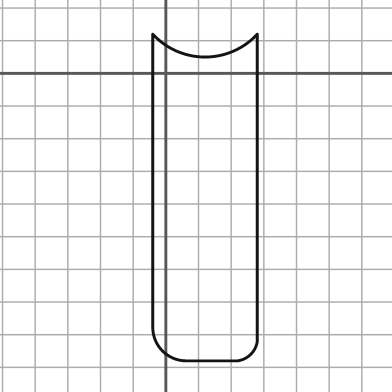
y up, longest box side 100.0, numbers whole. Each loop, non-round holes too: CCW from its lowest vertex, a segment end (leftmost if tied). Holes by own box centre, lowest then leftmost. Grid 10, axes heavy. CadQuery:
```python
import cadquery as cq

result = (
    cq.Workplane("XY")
    .moveTo(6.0, -88.0)
    .lineTo(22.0, -88.0)
    .threePointArc((26.0, -86.0), (28.0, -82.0))
    .lineTo(28.0, 12.0)
    .threePointArc((12.0, 5.0), (-4.0, 12.0))
    .lineTo(-4.0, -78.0)
    .threePointArc((-1.0, -85.0), (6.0, -88.0))
    .close()
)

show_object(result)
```